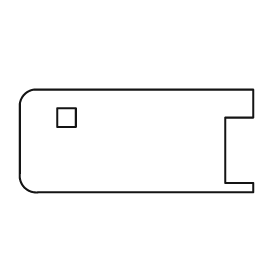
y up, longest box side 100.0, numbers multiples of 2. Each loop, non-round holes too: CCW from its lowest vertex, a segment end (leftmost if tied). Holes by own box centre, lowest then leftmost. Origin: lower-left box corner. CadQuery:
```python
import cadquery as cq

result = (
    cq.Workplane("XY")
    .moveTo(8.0, 0.0)
    .lineTo(100.0, 0.0)
    .lineTo(100.0, 4.0)
    .lineTo(88.0, 4.0)
    .lineTo(88.0, 32.0)
    .lineTo(100.0, 32.0)
    .lineTo(100.0, 44.0)
    .lineTo(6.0, 44.0)
    .threePointArc((2.0, 42.0), (0.0, 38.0))
    .lineTo(0.0, 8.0)
    .threePointArc((2.0, 2.0), (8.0, 0.0))
    .close()
    .moveTo(16.0, 28.0)
    .lineTo(24.0, 28.0)
    .lineTo(24.0, 36.0)
    .lineTo(16.0, 36.0)
    .close()
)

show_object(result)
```